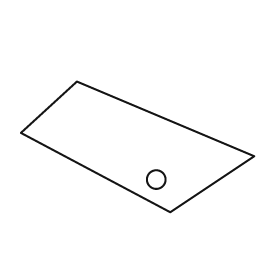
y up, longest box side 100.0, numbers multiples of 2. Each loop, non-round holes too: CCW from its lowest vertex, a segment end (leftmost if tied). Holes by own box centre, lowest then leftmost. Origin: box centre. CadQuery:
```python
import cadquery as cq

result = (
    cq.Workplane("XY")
    .moveTo(14.0, -28.0)
    .lineTo(50.0, -4.0)
    .lineTo(-26.0, 28.0)
    .lineTo(-50.0, 6.0)
    .close()
    .moveTo(8.0, -14.0)
    .circle(4.0)
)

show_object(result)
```